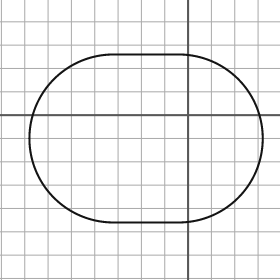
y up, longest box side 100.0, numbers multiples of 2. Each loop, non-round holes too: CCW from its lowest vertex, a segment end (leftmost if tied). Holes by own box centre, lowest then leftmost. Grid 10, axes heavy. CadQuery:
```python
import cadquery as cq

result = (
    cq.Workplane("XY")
    .moveTo(-32.0, -46.0)
    .lineTo(-4.0, -46.0)
    .threePointArc((32.0, -10.0), (-4.0, 26.0))
    .lineTo(-32.0, 26.0)
    .threePointArc((-68.0, -10.0), (-32.0, -46.0))
    .close()
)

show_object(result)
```